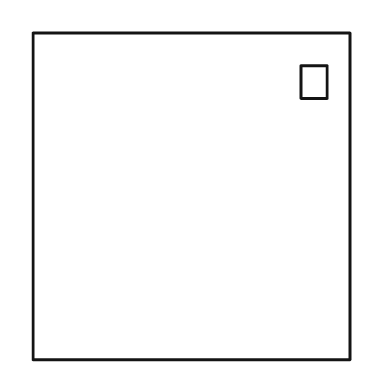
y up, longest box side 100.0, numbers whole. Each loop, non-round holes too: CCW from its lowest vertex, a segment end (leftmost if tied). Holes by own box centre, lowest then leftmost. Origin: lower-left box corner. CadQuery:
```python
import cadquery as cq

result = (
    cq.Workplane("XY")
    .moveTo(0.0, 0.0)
    .lineTo(97.0, 0.0)
    .lineTo(97.0, 100.0)
    .lineTo(0.0, 100.0)
    .close()
    .moveTo(82.0, 80.0)
    .lineTo(90.0, 80.0)
    .lineTo(90.0, 90.0)
    .lineTo(82.0, 90.0)
    .close()
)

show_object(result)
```